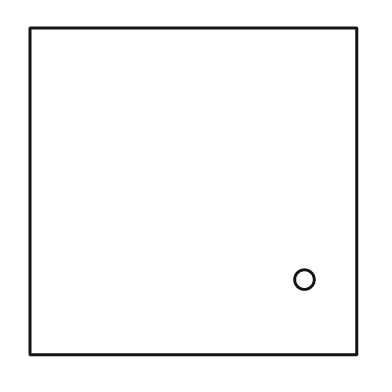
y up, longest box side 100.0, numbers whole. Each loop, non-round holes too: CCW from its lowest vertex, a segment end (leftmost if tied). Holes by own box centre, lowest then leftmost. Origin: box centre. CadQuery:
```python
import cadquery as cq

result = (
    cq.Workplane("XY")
    .moveTo(-50.0, -50.0)
    .lineTo(50.0, -50.0)
    .lineTo(50.0, 50.0)
    .lineTo(-50.0, 50.0)
    .close()
    .moveTo(34.0, -27.0)
    .circle(3.0)
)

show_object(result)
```